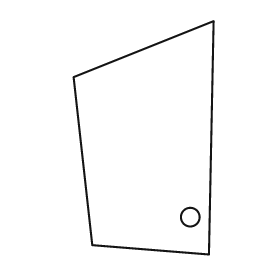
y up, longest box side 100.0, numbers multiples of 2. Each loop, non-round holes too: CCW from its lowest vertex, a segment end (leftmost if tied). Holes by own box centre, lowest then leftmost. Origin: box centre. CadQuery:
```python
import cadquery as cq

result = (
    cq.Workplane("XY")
    .moveTo(28.0, -50.0)
    .lineTo(30.0, 50.0)
    .lineTo(-30.0, 26.0)
    .lineTo(-22.0, -46.0)
    .close()
    .moveTo(20.0, -34.0)
    .circle(4.0)
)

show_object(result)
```